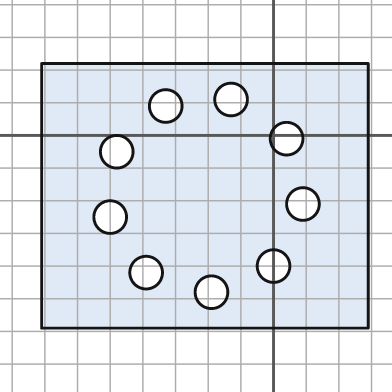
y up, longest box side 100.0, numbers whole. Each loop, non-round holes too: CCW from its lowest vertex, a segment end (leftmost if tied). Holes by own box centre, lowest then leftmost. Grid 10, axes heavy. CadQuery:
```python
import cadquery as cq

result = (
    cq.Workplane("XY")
    .moveTo(-71.0, -59.0)
    .lineTo(29.0, -59.0)
    .lineTo(29.0, 22.0)
    .lineTo(-71.0, 22.0)
    .close()
    .moveTo(-19.0, -48.0)
    .circle(5.0)
    .moveTo(-39.0, -42.0)
    .circle(5.0)
    .moveTo(0.0, -40.0)
    .circle(5.0)
    .moveTo(-50.0, -25.0)
    .circle(5.0)
    .moveTo(9.0, -21.0)
    .circle(5.0)
    .moveTo(-48.0, -5.0)
    .circle(5.0)
    .moveTo(4.0, -1.0)
    .circle(5.0)
    .moveTo(-33.0, 9.0)
    .circle(5.0)
    .moveTo(-13.0, 11.0)
    .circle(5.0)
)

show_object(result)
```